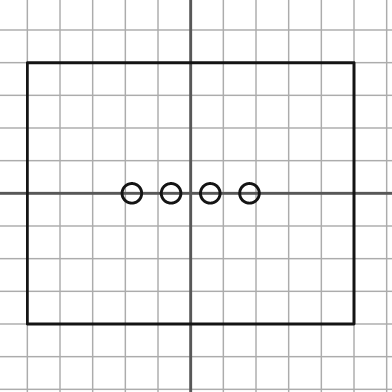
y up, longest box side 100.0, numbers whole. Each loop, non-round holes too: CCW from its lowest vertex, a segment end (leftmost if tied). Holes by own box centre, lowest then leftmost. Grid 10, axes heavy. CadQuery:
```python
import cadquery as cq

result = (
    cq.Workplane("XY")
    .moveTo(-50.0, -40.0)
    .lineTo(50.0, -40.0)
    .lineTo(50.0, 40.0)
    .lineTo(-50.0, 40.0)
    .close()
    .moveTo(-18.0, 0.0)
    .circle(3.0)
    .moveTo(-6.0, 0.0)
    .circle(3.0)
    .moveTo(6.0, 0.0)
    .circle(3.0)
    .moveTo(18.0, 0.0)
    .circle(3.0)
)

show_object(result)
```